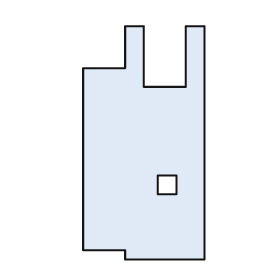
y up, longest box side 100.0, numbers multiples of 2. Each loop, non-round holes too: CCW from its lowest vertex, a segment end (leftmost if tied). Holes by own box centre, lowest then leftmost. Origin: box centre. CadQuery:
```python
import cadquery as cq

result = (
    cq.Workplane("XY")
    .moveTo(-8.0, -50.0)
    .lineTo(26.0, -50.0)
    .lineTo(26.0, 50.0)
    .lineTo(18.0, 50.0)
    .lineTo(18.0, 24.0)
    .lineTo(0.0, 24.0)
    .lineTo(0.0, 50.0)
    .lineTo(-8.0, 50.0)
    .lineTo(-8.0, 32.0)
    .lineTo(-26.0, 32.0)
    .lineTo(-26.0, -46.0)
    .lineTo(-8.0, -46.0)
    .close()
    .moveTo(6.0, -22.0)
    .lineTo(14.0, -22.0)
    .lineTo(14.0, -14.0)
    .lineTo(6.0, -14.0)
    .close()
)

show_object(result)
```